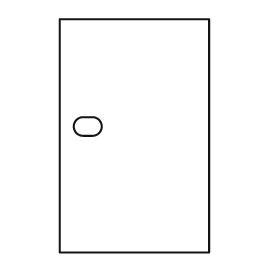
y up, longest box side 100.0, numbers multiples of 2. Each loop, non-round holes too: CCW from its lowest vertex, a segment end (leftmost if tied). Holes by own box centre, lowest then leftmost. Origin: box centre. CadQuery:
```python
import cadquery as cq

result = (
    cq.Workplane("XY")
    .moveTo(-32.0, -50.0)
    .lineTo(32.0, -50.0)
    .lineTo(32.0, 50.0)
    .lineTo(-32.0, 50.0)
    .close()
    .moveTo(-22.0, 0.0)
    .lineTo(-18.0, 0.0)
    .threePointArc((-14.0, 4.0), (-18.0, 8.0))
    .lineTo(-22.0, 8.0)
    .threePointArc((-26.0, 4.0), (-22.0, 0.0))
    .close()
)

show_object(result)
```